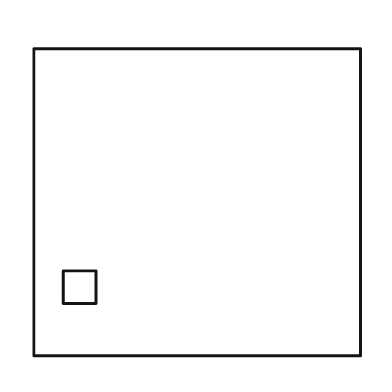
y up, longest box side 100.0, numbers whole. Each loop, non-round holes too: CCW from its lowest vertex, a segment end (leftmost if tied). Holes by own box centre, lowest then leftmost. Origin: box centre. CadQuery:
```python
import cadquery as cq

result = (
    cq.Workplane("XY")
    .moveTo(-50.0, -47.0)
    .lineTo(50.0, -47.0)
    .lineTo(50.0, 47.0)
    .lineTo(-50.0, 47.0)
    .close()
    .moveTo(-41.0, -31.0)
    .lineTo(-31.0, -31.0)
    .lineTo(-31.0, -21.0)
    .lineTo(-41.0, -21.0)
    .close()
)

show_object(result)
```